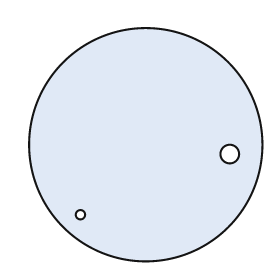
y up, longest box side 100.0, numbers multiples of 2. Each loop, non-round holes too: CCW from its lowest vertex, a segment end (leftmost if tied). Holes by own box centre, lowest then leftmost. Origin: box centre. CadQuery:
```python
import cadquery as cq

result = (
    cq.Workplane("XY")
    .moveTo(0.0, 0.0)
    .circle(50.0)
    .moveTo(-28.0, -30.0)
    .circle(2.0)
    .moveTo(36.0, -4.0)
    .circle(4.0)
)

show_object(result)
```